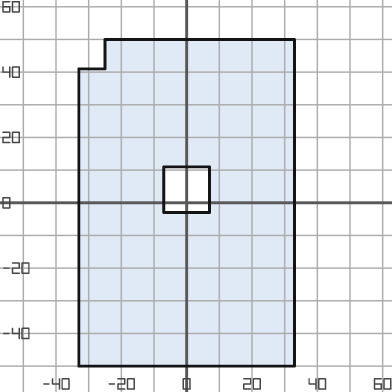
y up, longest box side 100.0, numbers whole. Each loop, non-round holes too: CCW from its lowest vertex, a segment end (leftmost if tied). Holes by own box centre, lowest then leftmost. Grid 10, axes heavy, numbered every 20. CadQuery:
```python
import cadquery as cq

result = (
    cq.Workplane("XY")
    .moveTo(-33.0, -50.0)
    .lineTo(33.0, -50.0)
    .lineTo(33.0, 50.0)
    .lineTo(-25.0, 50.0)
    .lineTo(-25.0, 41.0)
    .lineTo(-33.0, 41.0)
    .close()
    .moveTo(-7.0, -3.0)
    .lineTo(7.0, -3.0)
    .lineTo(7.0, 11.0)
    .lineTo(-7.0, 11.0)
    .close()
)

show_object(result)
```